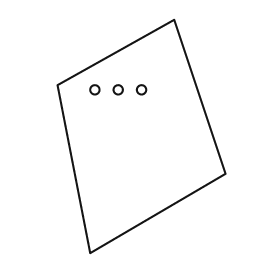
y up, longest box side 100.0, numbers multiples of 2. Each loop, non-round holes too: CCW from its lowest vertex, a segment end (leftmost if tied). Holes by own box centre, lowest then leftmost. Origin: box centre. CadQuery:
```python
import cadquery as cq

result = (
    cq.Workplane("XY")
    .moveTo(-22.0, -50.0)
    .lineTo(36.0, -16.0)
    .lineTo(14.0, 50.0)
    .lineTo(-36.0, 22.0)
    .close()
    .moveTo(-20.0, 20.0)
    .circle(2.0)
    .moveTo(-10.0, 20.0)
    .circle(2.0)
    .moveTo(0.0, 20.0)
    .circle(2.0)
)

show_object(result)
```